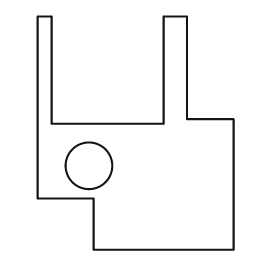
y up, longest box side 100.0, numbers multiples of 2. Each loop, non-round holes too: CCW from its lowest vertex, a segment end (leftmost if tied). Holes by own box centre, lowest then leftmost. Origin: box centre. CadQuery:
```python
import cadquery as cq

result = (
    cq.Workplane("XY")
    .moveTo(-18.0, -50.0)
    .lineTo(42.0, -50.0)
    .lineTo(42.0, 6.0)
    .lineTo(22.0, 6.0)
    .lineTo(22.0, 50.0)
    .lineTo(12.0, 50.0)
    .lineTo(12.0, 4.0)
    .lineTo(-36.0, 4.0)
    .lineTo(-36.0, 50.0)
    .lineTo(-42.0, 50.0)
    .lineTo(-42.0, -28.0)
    .lineTo(-18.0, -28.0)
    .close()
    .moveTo(-20.0, -14.0)
    .circle(10.0)
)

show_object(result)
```